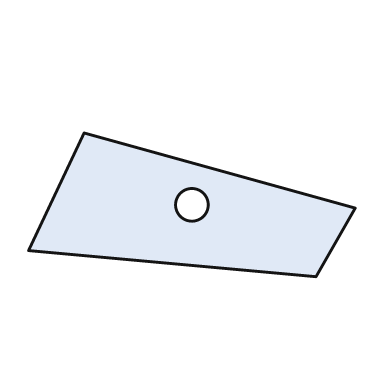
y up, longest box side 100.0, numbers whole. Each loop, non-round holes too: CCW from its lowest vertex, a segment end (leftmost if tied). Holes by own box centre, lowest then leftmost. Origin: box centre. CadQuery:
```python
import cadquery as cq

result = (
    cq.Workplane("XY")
    .moveTo(38.0, -22.0)
    .lineTo(50.0, -1.0)
    .lineTo(-33.0, 22.0)
    .lineTo(-50.0, -14.0)
    .close()
    .moveTo(0.0, 0.0)
    .circle(5.0)
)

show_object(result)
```